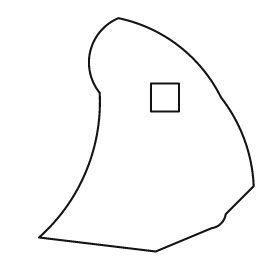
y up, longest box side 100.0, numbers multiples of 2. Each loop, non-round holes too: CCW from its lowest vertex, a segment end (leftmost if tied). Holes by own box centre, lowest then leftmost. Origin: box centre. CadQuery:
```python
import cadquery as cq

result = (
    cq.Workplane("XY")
    .moveTo(4.0, -50.0)
    .lineTo(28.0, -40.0)
    .threePointArc((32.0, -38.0), (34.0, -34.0))
    .lineTo(46.0, -22.0)
    .threePointArc((42.0, -2.0), (32.0, 16.0))
    .threePointArc((14.0, 38.0), (-12.0, 50.0))
    .threePointArc((-24.0, 36.0), (-20.0, 18.0))
    .threePointArc((-26.0, -16.0), (-46.0, -44.0))
    .close()
    .moveTo(2.0, 10.0)
    .lineTo(14.0, 10.0)
    .lineTo(14.0, 22.0)
    .lineTo(2.0, 22.0)
    .close()
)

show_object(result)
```